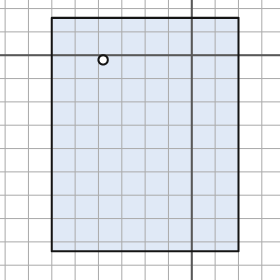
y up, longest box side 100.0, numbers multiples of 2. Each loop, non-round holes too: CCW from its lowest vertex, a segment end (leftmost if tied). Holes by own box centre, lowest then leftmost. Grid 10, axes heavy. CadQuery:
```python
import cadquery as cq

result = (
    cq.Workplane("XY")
    .moveTo(-60.0, -84.0)
    .lineTo(20.0, -84.0)
    .lineTo(20.0, 16.0)
    .lineTo(-60.0, 16.0)
    .close()
    .moveTo(-38.0, -2.0)
    .circle(2.0)
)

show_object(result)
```